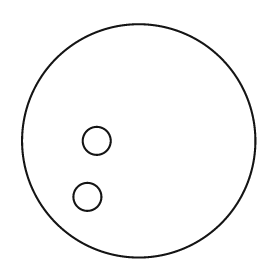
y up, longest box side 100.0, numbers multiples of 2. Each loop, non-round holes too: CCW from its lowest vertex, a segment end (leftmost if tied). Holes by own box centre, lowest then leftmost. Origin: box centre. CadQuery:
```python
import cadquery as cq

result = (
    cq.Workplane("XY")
    .moveTo(0.0, 0.0)
    .circle(50.0)
    .moveTo(-22.0, -24.0)
    .circle(6.0)
    .moveTo(-18.0, 0.0)
    .circle(6.0)
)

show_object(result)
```